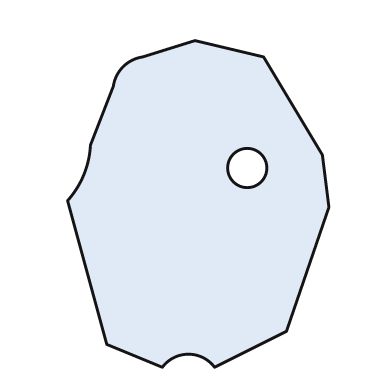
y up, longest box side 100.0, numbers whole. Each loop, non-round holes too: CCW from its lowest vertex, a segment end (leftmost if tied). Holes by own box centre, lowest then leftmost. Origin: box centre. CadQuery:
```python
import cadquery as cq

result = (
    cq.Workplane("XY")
    .moveTo(-11.0, -50.0)
    .threePointArc((-3.0, -46.0), (5.0, -50.0))
    .lineTo(27.0, -39.0)
    .lineTo(40.0, -1.0)
    .lineTo(38.0, 15.0)
    .lineTo(20.0, 45.0)
    .lineTo(-1.0, 50.0)
    .lineTo(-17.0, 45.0)
    .threePointArc((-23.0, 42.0), (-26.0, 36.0))
    .lineTo(-33.0, 18.0)
    .threePointArc((-35.0, 9.0), (-40.0, 1.0))
    .lineTo(-28.0, -43.0)
    .close()
    .moveTo(15.0, 11.0)
    .circle(6.0)
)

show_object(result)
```